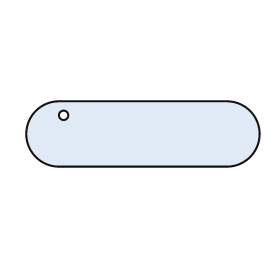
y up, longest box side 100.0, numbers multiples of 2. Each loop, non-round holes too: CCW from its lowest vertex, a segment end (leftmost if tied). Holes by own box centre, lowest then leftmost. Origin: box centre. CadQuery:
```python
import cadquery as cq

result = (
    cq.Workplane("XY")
    .moveTo(-36.0, -14.0)
    .lineTo(36.0, -14.0)
    .threePointArc((50.0, 0.0), (36.0, 14.0))
    .lineTo(-36.0, 14.0)
    .threePointArc((-50.0, 0.0), (-36.0, -14.0))
    .close()
    .moveTo(-34.0, 8.0)
    .circle(2.0)
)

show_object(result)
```